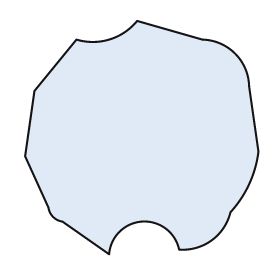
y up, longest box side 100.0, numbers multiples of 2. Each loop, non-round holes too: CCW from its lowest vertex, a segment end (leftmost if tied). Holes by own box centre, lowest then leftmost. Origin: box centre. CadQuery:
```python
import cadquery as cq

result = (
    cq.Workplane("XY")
    .moveTo(-14.0, -50.0)
    .threePointArc((0.0, -36.0), (16.0, -48.0))
    .threePointArc((30.0, -44.0), (38.0, -32.0))
    .threePointArc((46.0, -20.0), (50.0, -6.0))
    .lineTo(46.0, 22.0)
    .threePointArc((40.0, 36.0), (26.0, 42.0))
    .lineTo(-2.0, 50.0)
    .threePointArc((-14.0, 42.0), (-28.0, 42.0))
    .lineTo(-46.0, 20.0)
    .lineTo(-50.0, -8.0)
    .lineTo(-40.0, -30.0)
    .threePointArc((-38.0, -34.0), (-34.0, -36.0))
    .close()
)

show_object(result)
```